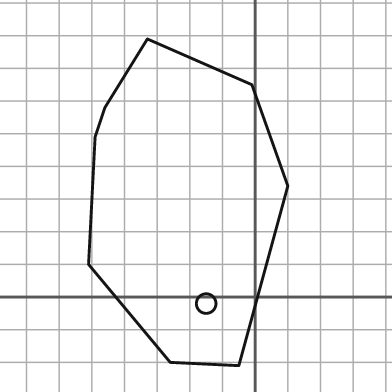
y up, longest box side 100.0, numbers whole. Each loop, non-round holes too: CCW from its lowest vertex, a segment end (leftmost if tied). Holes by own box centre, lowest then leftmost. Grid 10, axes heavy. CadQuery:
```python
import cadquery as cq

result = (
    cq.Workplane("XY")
    .moveTo(-5.0, -21.0)
    .lineTo(10.0, 34.0)
    .lineTo(-1.0, 65.0)
    .lineTo(-33.0, 79.0)
    .lineTo(-46.0, 58.0)
    .lineTo(-49.0, 49.0)
    .lineTo(-51.0, 10.0)
    .lineTo(-26.0, -20.0)
    .close()
    .moveTo(-15.0, -2.0)
    .circle(3.0)
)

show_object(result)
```